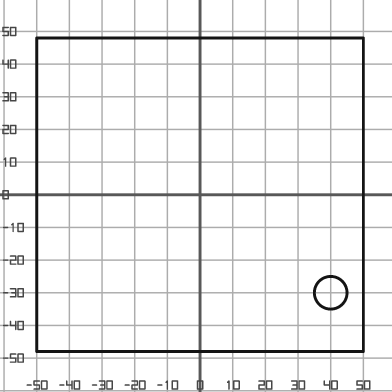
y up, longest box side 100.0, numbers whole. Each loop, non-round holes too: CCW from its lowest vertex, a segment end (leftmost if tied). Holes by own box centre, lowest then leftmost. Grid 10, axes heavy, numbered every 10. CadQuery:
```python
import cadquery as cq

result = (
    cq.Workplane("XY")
    .moveTo(-50.0, -48.0)
    .lineTo(50.0, -48.0)
    .lineTo(50.0, 48.0)
    .lineTo(-50.0, 48.0)
    .close()
    .moveTo(40.0, -30.0)
    .circle(5.0)
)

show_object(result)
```